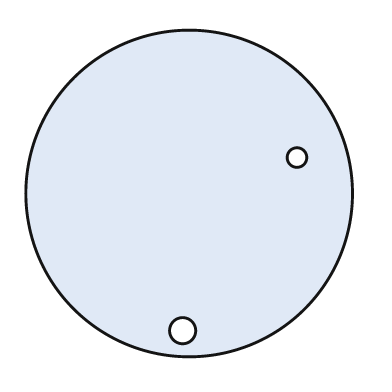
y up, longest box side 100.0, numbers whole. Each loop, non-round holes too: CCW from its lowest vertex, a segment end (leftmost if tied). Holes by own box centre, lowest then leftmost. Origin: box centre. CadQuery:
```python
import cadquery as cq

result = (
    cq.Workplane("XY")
    .moveTo(0.0, 0.0)
    .circle(50.0)
    .moveTo(-2.0, -42.0)
    .circle(4.0)
    .moveTo(33.0, 11.0)
    .circle(3.0)
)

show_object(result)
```